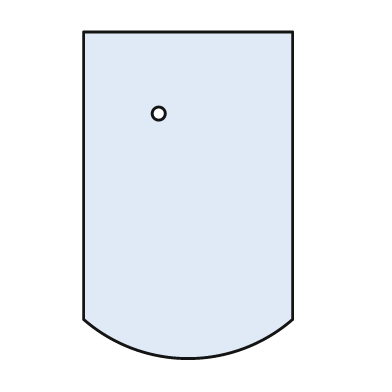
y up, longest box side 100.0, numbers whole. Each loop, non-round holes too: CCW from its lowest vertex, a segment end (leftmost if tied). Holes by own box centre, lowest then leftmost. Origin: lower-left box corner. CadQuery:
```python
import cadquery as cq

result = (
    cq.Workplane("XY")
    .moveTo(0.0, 12.0)
    .threePointArc((32.0, 0.0), (64.0, 12.0))
    .lineTo(64.0, 100.0)
    .lineTo(0.0, 100.0)
    .close()
    .moveTo(23.0, 75.0)
    .circle(2.0)
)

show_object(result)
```